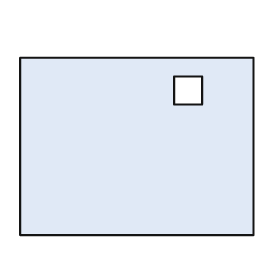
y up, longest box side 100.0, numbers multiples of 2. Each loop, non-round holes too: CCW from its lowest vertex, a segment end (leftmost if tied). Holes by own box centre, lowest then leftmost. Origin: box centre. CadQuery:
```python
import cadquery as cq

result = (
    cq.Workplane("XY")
    .moveTo(-50.0, -38.0)
    .lineTo(50.0, -38.0)
    .lineTo(50.0, 38.0)
    .lineTo(-50.0, 38.0)
    .close()
    .moveTo(16.0, 18.0)
    .lineTo(28.0, 18.0)
    .lineTo(28.0, 30.0)
    .lineTo(16.0, 30.0)
    .close()
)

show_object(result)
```